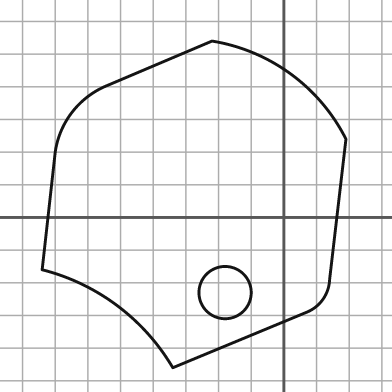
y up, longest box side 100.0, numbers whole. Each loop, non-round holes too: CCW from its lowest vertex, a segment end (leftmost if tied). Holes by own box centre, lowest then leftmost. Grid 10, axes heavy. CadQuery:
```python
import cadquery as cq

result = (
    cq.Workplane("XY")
    .moveTo(-34.0, -46.0)
    .lineTo(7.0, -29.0)
    .threePointArc((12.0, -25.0), (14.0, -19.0))
    .lineTo(19.0, 24.0)
    .threePointArc((2.0, 44.0), (-22.0, 54.0))
    .lineTo(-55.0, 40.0)
    .threePointArc((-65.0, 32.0), (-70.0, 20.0))
    .lineTo(-74.0, -16.0)
    .threePointArc((-51.0, -27.0), (-34.0, -46.0))
    .close()
    .moveTo(-18.0, -23.0)
    .circle(8.0)
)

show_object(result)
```